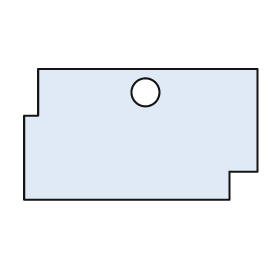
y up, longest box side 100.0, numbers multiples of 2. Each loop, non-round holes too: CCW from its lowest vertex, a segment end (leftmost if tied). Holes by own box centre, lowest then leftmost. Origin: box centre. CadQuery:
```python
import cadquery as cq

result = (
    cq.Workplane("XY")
    .moveTo(-50.0, -28.0)
    .lineTo(38.0, -28.0)
    .lineTo(38.0, -16.0)
    .lineTo(50.0, -16.0)
    .lineTo(50.0, 28.0)
    .lineTo(-44.0, 28.0)
    .lineTo(-44.0, 8.0)
    .lineTo(-50.0, 8.0)
    .close()
    .moveTo(2.0, 18.0)
    .circle(6.0)
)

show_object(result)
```